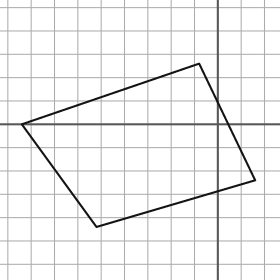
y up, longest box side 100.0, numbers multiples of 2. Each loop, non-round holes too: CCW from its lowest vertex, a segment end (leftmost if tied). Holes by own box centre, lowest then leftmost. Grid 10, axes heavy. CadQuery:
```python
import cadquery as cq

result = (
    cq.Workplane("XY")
    .moveTo(-52.0, -44.0)
    .lineTo(16.0, -24.0)
    .lineTo(-8.0, 26.0)
    .lineTo(-84.0, 0.0)
    .close()
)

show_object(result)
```